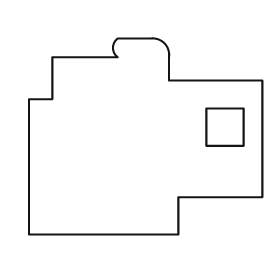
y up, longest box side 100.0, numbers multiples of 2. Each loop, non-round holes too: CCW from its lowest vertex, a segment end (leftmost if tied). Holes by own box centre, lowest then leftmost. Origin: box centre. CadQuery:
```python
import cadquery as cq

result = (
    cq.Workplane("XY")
    .moveTo(-50.0, -42.0)
    .lineTo(14.0, -42.0)
    .lineTo(14.0, -26.0)
    .lineTo(50.0, -26.0)
    .lineTo(50.0, 24.0)
    .lineTo(10.0, 24.0)
    .lineTo(10.0, 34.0)
    .threePointArc((8.0, 40.0), (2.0, 42.0))
    .lineTo(-12.0, 42.0)
    .threePointArc((-14.0, 38.0), (-12.0, 34.0))
    .lineTo(-40.0, 34.0)
    .lineTo(-40.0, 16.0)
    .lineTo(-50.0, 16.0)
    .close()
    .moveTo(26.0, -4.0)
    .lineTo(42.0, -4.0)
    .lineTo(42.0, 12.0)
    .lineTo(26.0, 12.0)
    .close()
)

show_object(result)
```